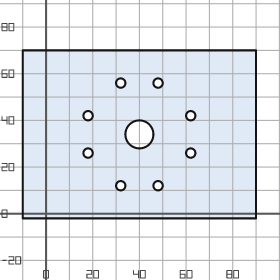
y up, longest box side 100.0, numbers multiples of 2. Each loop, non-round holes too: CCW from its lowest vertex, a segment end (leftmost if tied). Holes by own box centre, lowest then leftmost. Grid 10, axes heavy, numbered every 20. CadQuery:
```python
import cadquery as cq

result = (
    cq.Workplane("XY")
    .moveTo(-10.0, -2.0)
    .lineTo(90.0, -2.0)
    .lineTo(90.0, 70.0)
    .lineTo(-10.0, 70.0)
    .close()
    .moveTo(32.0, 12.0)
    .circle(2.0)
    .moveTo(48.0, 12.0)
    .circle(2.0)
    .moveTo(18.0, 26.0)
    .circle(2.0)
    .moveTo(62.0, 26.0)
    .circle(2.0)
    .moveTo(40.0, 34.0)
    .circle(6.0)
    .moveTo(18.0, 42.0)
    .circle(2.0)
    .moveTo(62.0, 42.0)
    .circle(2.0)
    .moveTo(32.0, 56.0)
    .circle(2.0)
    .moveTo(48.0, 56.0)
    .circle(2.0)
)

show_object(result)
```